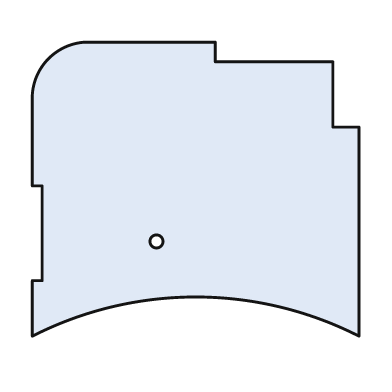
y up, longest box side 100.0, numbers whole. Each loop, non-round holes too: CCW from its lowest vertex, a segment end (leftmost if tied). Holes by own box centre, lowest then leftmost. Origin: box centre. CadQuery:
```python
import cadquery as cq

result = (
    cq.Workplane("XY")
    .moveTo(-50.0, -45.0)
    .threePointArc((0.0, -33.0), (50.0, -45.0))
    .lineTo(50.0, 19.0)
    .lineTo(42.0, 19.0)
    .lineTo(42.0, 39.0)
    .lineTo(6.0, 39.0)
    .lineTo(6.0, 45.0)
    .lineTo(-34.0, 45.0)
    .threePointArc((-45.0, 40.0), (-50.0, 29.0))
    .lineTo(-50.0, 1.0)
    .lineTo(-47.0, 1.0)
    .lineTo(-47.0, -28.0)
    .lineTo(-50.0, -28.0)
    .close()
    .moveTo(-12.0, -16.0)
    .circle(2.0)
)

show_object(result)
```